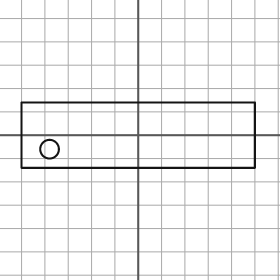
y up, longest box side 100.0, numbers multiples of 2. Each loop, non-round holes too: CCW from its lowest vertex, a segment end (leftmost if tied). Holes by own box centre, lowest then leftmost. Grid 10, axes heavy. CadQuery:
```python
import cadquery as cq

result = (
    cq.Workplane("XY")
    .moveTo(-50.0, -14.0)
    .lineTo(50.0, -14.0)
    .lineTo(50.0, 14.0)
    .lineTo(-50.0, 14.0)
    .close()
    .moveTo(-38.0, -6.0)
    .circle(4.0)
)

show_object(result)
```